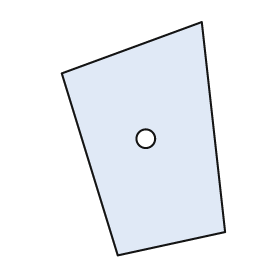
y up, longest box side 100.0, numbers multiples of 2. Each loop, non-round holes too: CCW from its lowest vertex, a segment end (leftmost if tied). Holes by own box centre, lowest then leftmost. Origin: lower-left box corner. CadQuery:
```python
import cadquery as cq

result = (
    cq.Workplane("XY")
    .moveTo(24.0, 0.0)
    .lineTo(70.0, 10.0)
    .lineTo(60.0, 100.0)
    .lineTo(0.0, 78.0)
    .close()
    .moveTo(36.0, 50.0)
    .circle(4.0)
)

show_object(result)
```